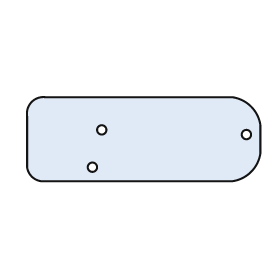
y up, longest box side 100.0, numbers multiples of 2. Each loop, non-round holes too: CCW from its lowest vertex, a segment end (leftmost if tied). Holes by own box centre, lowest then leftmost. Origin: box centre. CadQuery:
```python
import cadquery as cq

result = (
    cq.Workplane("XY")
    .moveTo(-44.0, -18.0)
    .lineTo(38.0, -18.0)
    .threePointArc((46.0, -14.0), (50.0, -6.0))
    .lineTo(50.0, 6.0)
    .threePointArc((46.0, 14.0), (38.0, 18.0))
    .lineTo(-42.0, 18.0)
    .threePointArc((-48.0, 16.0), (-50.0, 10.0))
    .lineTo(-50.0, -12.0)
    .threePointArc((-48.0, -16.0), (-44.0, -18.0))
    .close()
    .moveTo(-22.0, -12.0)
    .circle(2.0)
    .moveTo(44.0, 2.0)
    .circle(2.0)
    .moveTo(-18.0, 4.0)
    .circle(2.0)
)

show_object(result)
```